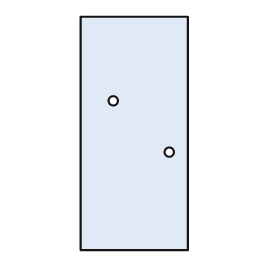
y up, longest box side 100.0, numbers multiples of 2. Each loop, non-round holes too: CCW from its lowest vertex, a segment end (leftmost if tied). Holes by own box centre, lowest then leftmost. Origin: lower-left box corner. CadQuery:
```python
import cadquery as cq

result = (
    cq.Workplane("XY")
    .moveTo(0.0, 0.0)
    .lineTo(46.0, 0.0)
    .lineTo(46.0, 100.0)
    .lineTo(0.0, 100.0)
    .close()
    .moveTo(38.0, 42.0)
    .circle(2.0)
    .moveTo(14.0, 64.0)
    .circle(2.0)
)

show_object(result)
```